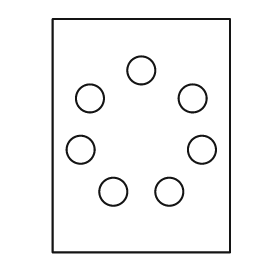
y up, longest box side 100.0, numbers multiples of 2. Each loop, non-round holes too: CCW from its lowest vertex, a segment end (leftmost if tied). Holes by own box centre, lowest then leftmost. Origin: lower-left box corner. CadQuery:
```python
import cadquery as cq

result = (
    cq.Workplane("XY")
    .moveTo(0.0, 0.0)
    .lineTo(76.0, 0.0)
    .lineTo(76.0, 100.0)
    .lineTo(0.0, 100.0)
    .close()
    .moveTo(26.0, 26.0)
    .circle(6.0)
    .moveTo(50.0, 26.0)
    .circle(6.0)
    .moveTo(12.0, 44.0)
    .circle(6.0)
    .moveTo(64.0, 44.0)
    .circle(6.0)
    .moveTo(16.0, 66.0)
    .circle(6.0)
    .moveTo(60.0, 66.0)
    .circle(6.0)
    .moveTo(38.0, 78.0)
    .circle(6.0)
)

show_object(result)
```